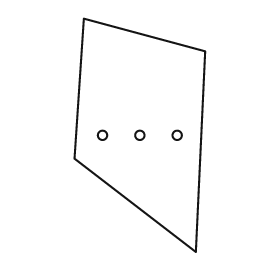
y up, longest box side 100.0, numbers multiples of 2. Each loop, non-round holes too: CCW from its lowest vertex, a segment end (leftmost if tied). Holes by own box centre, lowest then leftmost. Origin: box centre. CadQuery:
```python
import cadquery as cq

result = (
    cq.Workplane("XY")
    .moveTo(24.0, -50.0)
    .lineTo(28.0, 36.0)
    .lineTo(-24.0, 50.0)
    .lineTo(-28.0, -10.0)
    .close()
    .moveTo(-16.0, 0.0)
    .circle(2.0)
    .moveTo(0.0, 0.0)
    .circle(2.0)
    .moveTo(16.0, 0.0)
    .circle(2.0)
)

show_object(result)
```